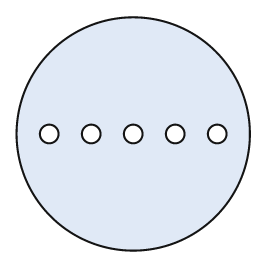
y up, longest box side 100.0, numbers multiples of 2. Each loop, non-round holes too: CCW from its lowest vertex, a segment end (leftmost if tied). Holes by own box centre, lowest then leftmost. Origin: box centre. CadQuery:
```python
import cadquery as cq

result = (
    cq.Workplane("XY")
    .moveTo(0.0, 0.0)
    .circle(50.0)
    .moveTo(-36.0, 0.0)
    .circle(4.0)
    .moveTo(-18.0, 0.0)
    .circle(4.0)
    .moveTo(0.0, 0.0)
    .circle(4.0)
    .moveTo(18.0, 0.0)
    .circle(4.0)
    .moveTo(36.0, 0.0)
    .circle(4.0)
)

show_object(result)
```